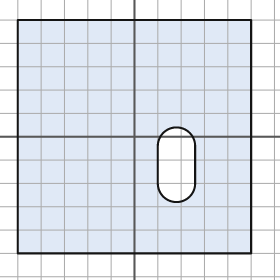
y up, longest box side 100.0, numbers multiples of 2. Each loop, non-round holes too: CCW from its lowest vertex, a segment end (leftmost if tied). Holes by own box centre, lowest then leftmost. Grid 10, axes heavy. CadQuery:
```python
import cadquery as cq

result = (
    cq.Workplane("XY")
    .moveTo(-50.0, -50.0)
    .lineTo(50.0, -50.0)
    .lineTo(50.0, 50.0)
    .lineTo(-50.0, 50.0)
    .close()
    .moveTo(10.0, -20.0)
    .threePointArc((18.0, -28.0), (26.0, -20.0))
    .lineTo(26.0, -4.0)
    .threePointArc((18.0, 4.0), (10.0, -4.0))
    .close()
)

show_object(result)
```